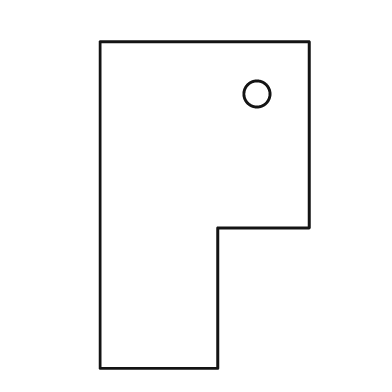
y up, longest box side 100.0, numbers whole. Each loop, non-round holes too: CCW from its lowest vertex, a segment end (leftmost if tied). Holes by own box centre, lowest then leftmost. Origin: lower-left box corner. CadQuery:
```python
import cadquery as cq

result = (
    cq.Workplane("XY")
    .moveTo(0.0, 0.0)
    .lineTo(36.0, 0.0)
    .lineTo(36.0, 43.0)
    .lineTo(64.0, 43.0)
    .lineTo(64.0, 100.0)
    .lineTo(0.0, 100.0)
    .close()
    .moveTo(48.0, 84.0)
    .circle(4.0)
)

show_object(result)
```